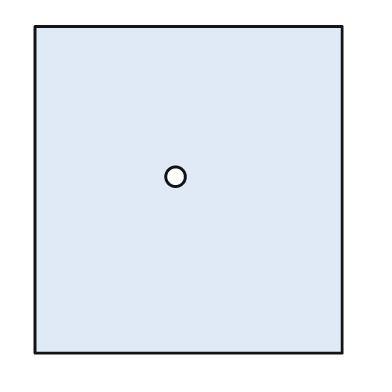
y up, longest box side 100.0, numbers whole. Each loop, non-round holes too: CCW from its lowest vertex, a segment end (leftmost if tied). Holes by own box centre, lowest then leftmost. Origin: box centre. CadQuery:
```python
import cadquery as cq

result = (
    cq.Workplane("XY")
    .moveTo(-47.0, -50.0)
    .lineTo(47.0, -50.0)
    .lineTo(47.0, 50.0)
    .lineTo(-47.0, 50.0)
    .close()
    .moveTo(-4.0, 4.0)
    .circle(3.0)
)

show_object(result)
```